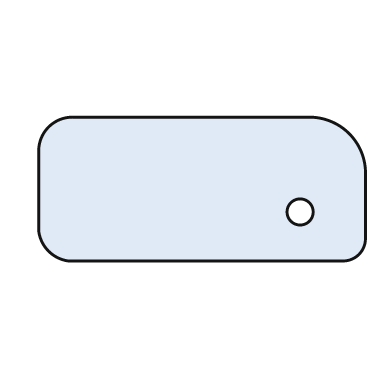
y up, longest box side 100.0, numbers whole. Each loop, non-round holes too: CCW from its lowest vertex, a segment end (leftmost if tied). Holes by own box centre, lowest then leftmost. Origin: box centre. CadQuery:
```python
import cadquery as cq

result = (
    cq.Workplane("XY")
    .moveTo(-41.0, -22.0)
    .lineTo(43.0, -22.0)
    .threePointArc((48.0, -20.0), (50.0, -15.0))
    .lineTo(50.0, 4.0)
    .threePointArc((45.0, 17.0), (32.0, 22.0))
    .lineTo(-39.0, 22.0)
    .threePointArc((-47.0, 19.0), (-50.0, 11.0))
    .lineTo(-50.0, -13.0)
    .threePointArc((-47.0, -19.0), (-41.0, -22.0))
    .close()
    .moveTo(30.0, -7.0)
    .circle(4.0)
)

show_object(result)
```